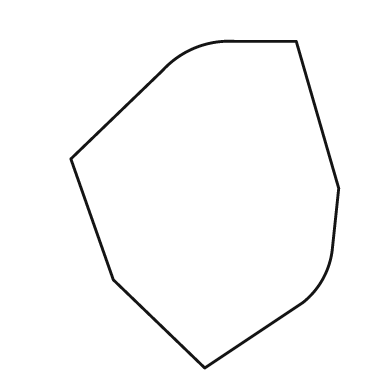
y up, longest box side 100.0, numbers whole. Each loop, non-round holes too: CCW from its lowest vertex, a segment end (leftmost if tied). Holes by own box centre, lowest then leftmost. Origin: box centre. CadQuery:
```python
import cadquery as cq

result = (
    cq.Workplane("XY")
    .moveTo(0.0, -50.0)
    .lineTo(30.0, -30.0)
    .threePointArc((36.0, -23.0), (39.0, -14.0))
    .lineTo(41.0, 5.0)
    .lineTo(28.0, 50.0)
    .lineTo(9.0, 50.0)
    .threePointArc((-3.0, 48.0), (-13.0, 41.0))
    .lineTo(-41.0, 14.0)
    .lineTo(-28.0, -23.0)
    .close()
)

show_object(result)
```